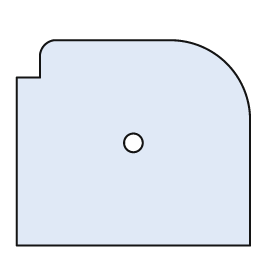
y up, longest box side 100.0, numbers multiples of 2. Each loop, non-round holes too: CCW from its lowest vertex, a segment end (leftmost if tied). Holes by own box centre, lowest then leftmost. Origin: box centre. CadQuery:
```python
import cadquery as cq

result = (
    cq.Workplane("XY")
    .moveTo(-50.0, -44.0)
    .lineTo(50.0, -44.0)
    .lineTo(50.0, 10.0)
    .threePointArc((40.0, 34.0), (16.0, 44.0))
    .lineTo(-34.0, 44.0)
    .threePointArc((-38.0, 42.0), (-40.0, 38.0))
    .lineTo(-40.0, 28.0)
    .lineTo(-50.0, 28.0)
    .close()
    .moveTo(0.0, 0.0)
    .circle(4.0)
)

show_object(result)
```